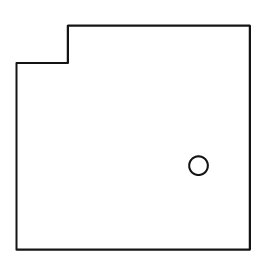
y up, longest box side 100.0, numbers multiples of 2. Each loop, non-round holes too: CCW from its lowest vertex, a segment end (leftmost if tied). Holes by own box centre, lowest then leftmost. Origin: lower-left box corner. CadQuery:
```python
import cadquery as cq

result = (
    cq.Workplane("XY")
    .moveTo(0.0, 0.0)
    .lineTo(100.0, 0.0)
    .lineTo(100.0, 96.0)
    .lineTo(22.0, 96.0)
    .lineTo(22.0, 80.0)
    .lineTo(0.0, 80.0)
    .close()
    .moveTo(78.0, 36.0)
    .circle(4.0)
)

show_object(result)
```